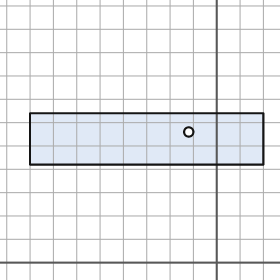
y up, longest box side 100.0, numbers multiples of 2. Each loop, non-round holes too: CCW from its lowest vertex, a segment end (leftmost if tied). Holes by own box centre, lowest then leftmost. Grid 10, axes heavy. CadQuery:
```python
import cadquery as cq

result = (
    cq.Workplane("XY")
    .moveTo(-80.0, 42.0)
    .lineTo(20.0, 42.0)
    .lineTo(20.0, 64.0)
    .lineTo(-80.0, 64.0)
    .close()
    .moveTo(-12.0, 56.0)
    .circle(2.0)
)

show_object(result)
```